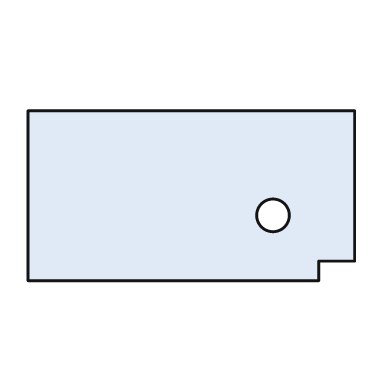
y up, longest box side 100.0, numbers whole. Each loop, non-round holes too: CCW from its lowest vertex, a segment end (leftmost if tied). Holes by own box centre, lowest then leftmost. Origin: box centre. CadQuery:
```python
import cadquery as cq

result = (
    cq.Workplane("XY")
    .moveTo(-50.0, -26.0)
    .lineTo(39.0, -26.0)
    .lineTo(39.0, -20.0)
    .lineTo(50.0, -20.0)
    .lineTo(50.0, 26.0)
    .lineTo(-50.0, 26.0)
    .close()
    .moveTo(25.0, -6.0)
    .circle(5.0)
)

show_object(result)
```